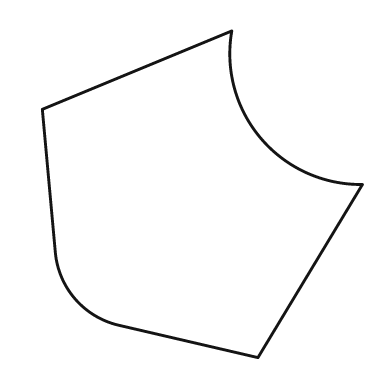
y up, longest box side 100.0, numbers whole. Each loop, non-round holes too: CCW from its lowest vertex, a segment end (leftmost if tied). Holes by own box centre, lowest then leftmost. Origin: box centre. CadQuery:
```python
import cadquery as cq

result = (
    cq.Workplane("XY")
    .moveTo(17.0, -50.0)
    .lineTo(49.0, 3.0)
    .threePointArc((18.0, 17.0), (9.0, 50.0))
    .lineTo(-49.0, 26.0)
    .lineTo(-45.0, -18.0)
    .threePointArc((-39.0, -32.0), (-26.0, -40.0))
    .close()
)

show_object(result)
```